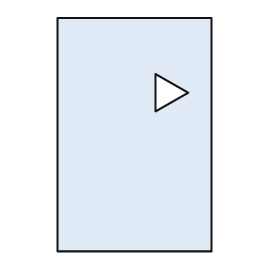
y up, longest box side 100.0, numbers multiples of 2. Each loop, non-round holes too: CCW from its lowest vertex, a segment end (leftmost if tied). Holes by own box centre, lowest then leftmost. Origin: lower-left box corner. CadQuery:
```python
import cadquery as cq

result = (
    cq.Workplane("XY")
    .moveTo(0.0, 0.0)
    .lineTo(66.0, 0.0)
    .lineTo(66.0, 100.0)
    .lineTo(0.0, 100.0)
    .close()
    .moveTo(42.0, 60.0)
    .lineTo(56.0, 68.0)
    .lineTo(42.0, 76.0)
    .close()
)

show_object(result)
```